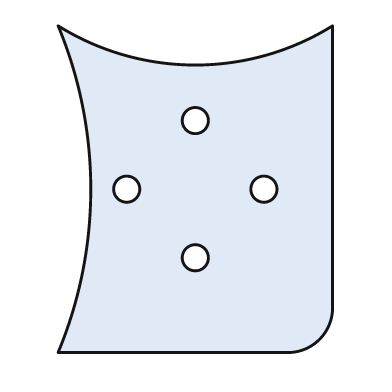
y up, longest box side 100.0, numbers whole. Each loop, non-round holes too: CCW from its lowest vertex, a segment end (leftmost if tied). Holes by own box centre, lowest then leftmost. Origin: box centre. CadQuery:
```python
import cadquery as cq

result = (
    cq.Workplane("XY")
    .moveTo(-42.0, -50.0)
    .lineTo(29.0, -50.0)
    .threePointArc((38.0, -46.0), (42.0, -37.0))
    .lineTo(42.0, 50.0)
    .threePointArc((0.0, 38.0), (-42.0, 50.0))
    .threePointArc((-32.0, 0.0), (-42.0, -50.0))
    .close()
    .moveTo(0.0, -21.0)
    .circle(4.0)
    .moveTo(-21.0, 0.0)
    .circle(4.0)
    .moveTo(21.0, 0.0)
    .circle(4.0)
    .moveTo(0.0, 21.0)
    .circle(4.0)
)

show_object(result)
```